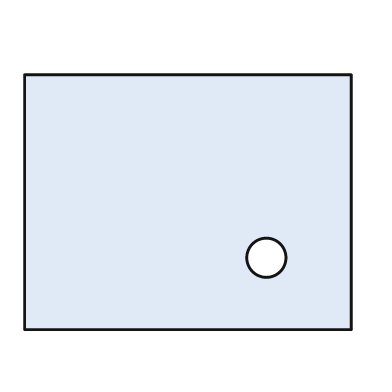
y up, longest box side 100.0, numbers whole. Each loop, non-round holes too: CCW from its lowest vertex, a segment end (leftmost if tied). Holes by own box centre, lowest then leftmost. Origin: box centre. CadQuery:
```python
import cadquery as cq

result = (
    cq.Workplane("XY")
    .moveTo(-50.0, -39.0)
    .lineTo(50.0, -39.0)
    .lineTo(50.0, 39.0)
    .lineTo(-50.0, 39.0)
    .close()
    .moveTo(24.0, -17.0)
    .circle(6.0)
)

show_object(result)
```